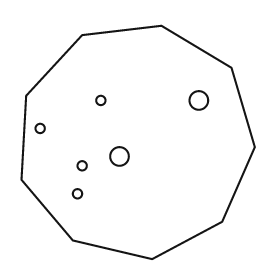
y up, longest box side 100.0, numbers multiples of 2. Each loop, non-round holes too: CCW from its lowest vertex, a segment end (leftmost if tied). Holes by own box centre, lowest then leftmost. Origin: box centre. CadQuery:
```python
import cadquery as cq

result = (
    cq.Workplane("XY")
    .moveTo(6.0, -50.0)
    .lineTo(36.0, -34.0)
    .lineTo(50.0, -2.0)
    .lineTo(40.0, 32.0)
    .lineTo(10.0, 50.0)
    .lineTo(-24.0, 46.0)
    .lineTo(-48.0, 20.0)
    .lineTo(-50.0, -16.0)
    .lineTo(-28.0, -42.0)
    .close()
    .moveTo(-26.0, -22.0)
    .circle(2.0)
    .moveTo(-24.0, -10.0)
    .circle(2.0)
    .moveTo(-8.0, -6.0)
    .circle(4.0)
    .moveTo(-42.0, 6.0)
    .circle(2.0)
    .moveTo(-16.0, 18.0)
    .circle(2.0)
    .moveTo(26.0, 18.0)
    .circle(4.0)
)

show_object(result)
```